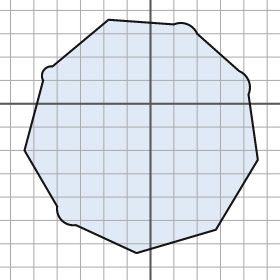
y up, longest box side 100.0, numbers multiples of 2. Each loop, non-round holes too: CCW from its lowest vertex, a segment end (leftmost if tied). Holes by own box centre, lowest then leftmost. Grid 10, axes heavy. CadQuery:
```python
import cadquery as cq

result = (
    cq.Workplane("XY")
    .moveTo(-6.0, -64.0)
    .lineTo(28.0, -54.0)
    .lineTo(46.0, -24.0)
    .lineTo(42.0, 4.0)
    .threePointArc((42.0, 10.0), (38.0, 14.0))
    .lineTo(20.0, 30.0)
    .threePointArc((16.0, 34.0), (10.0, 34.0))
    .lineTo(-18.0, 36.0)
    .lineTo(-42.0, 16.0)
    .threePointArc((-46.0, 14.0), (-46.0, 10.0))
    .lineTo(-54.0, -20.0)
    .lineTo(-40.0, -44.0)
    .threePointArc((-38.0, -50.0), (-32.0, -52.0))
    .close()
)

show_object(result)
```